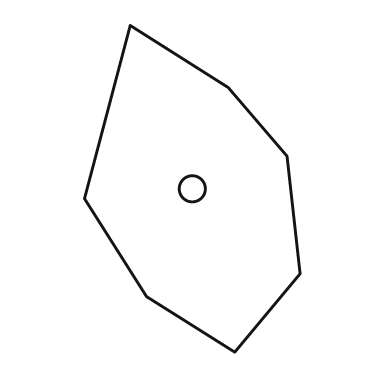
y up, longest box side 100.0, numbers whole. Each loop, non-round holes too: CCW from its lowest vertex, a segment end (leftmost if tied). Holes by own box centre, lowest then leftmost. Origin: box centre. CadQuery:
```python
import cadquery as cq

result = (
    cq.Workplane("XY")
    .moveTo(13.0, -50.0)
    .lineTo(33.0, -26.0)
    .lineTo(29.0, 10.0)
    .lineTo(11.0, 31.0)
    .lineTo(-19.0, 50.0)
    .lineTo(-33.0, -3.0)
    .lineTo(-14.0, -33.0)
    .close()
    .moveTo(0.0, 0.0)
    .circle(4.0)
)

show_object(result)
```